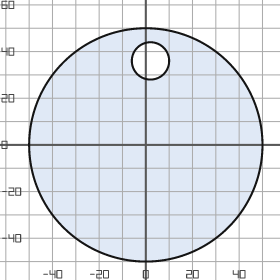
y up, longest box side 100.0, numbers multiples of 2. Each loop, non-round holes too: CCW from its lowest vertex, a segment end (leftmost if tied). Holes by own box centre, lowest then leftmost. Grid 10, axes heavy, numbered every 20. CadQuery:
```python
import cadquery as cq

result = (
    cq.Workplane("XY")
    .moveTo(0.0, 0.0)
    .circle(50.0)
    .moveTo(2.0, 36.0)
    .circle(8.0)
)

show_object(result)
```